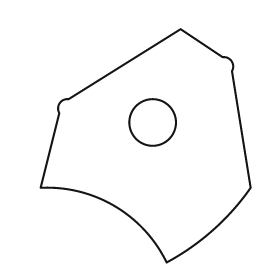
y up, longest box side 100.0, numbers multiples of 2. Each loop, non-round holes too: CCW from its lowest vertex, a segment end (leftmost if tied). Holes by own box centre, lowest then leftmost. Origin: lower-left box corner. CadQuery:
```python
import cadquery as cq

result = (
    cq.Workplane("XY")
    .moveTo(54.0, 0.0)
    .threePointArc((74.0, 14.0), (90.0, 32.0))
    .lineTo(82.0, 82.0)
    .threePointArc((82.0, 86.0), (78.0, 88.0))
    .lineTo(60.0, 100.0)
    .lineTo(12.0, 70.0)
    .threePointArc((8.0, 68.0), (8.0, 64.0))
    .lineTo(0.0, 32.0)
    .threePointArc((32.0, 24.0), (54.0, 0.0))
    .close()
    .moveTo(48.0, 60.0)
    .circle(10.0)
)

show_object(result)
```